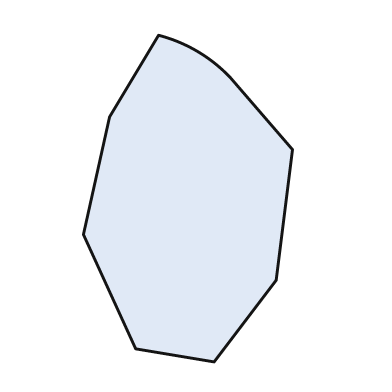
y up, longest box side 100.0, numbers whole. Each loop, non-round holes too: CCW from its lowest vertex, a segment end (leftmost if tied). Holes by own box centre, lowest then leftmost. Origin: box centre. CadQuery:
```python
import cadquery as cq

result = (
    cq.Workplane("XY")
    .moveTo(8.0, -50.0)
    .lineTo(27.0, -25.0)
    .lineTo(32.0, 15.0)
    .lineTo(13.0, 37.0)
    .threePointArc((3.0, 45.0), (-9.0, 50.0))
    .lineTo(-24.0, 25.0)
    .lineTo(-32.0, -11.0)
    .lineTo(-16.0, -46.0)
    .close()
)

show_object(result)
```